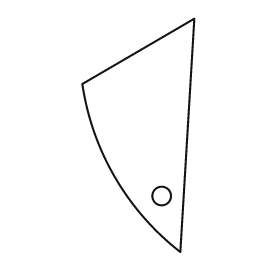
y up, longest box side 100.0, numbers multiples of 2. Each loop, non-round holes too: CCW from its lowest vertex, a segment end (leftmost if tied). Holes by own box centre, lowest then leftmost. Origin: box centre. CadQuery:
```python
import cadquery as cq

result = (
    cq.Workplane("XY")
    .moveTo(18.0, -50.0)
    .lineTo(24.0, 50.0)
    .lineTo(-24.0, 22.0)
    .threePointArc((-10.0, -18.0), (18.0, -50.0))
    .close()
    .moveTo(10.0, -26.0)
    .circle(4.0)
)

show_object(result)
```